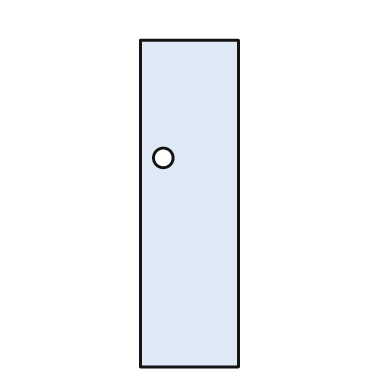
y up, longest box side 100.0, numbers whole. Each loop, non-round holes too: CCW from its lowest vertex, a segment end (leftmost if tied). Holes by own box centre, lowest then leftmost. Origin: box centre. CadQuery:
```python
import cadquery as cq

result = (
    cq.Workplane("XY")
    .moveTo(-15.0, -50.0)
    .lineTo(15.0, -50.0)
    .lineTo(15.0, 50.0)
    .lineTo(-15.0, 50.0)
    .close()
    .moveTo(-8.0, 14.0)
    .circle(3.0)
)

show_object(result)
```